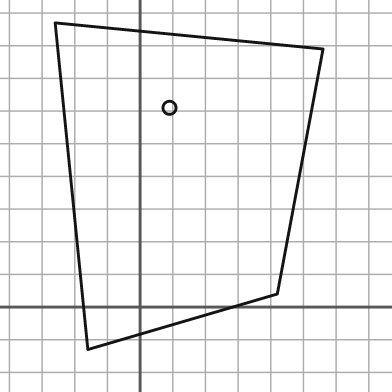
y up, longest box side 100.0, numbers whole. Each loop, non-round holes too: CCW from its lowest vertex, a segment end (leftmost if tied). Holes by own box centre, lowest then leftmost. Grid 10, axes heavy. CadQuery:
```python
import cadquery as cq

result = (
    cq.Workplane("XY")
    .moveTo(-16.0, -13.0)
    .lineTo(42.0, 4.0)
    .lineTo(56.0, 79.0)
    .lineTo(-26.0, 87.0)
    .close()
    .moveTo(9.0, 61.0)
    .circle(2.0)
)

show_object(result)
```